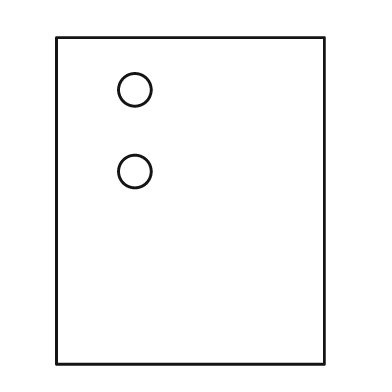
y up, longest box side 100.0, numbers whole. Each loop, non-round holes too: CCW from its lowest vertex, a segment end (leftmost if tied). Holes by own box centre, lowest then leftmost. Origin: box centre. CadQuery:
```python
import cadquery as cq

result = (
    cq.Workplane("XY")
    .moveTo(-41.0, -50.0)
    .lineTo(41.0, -50.0)
    .lineTo(41.0, 50.0)
    .lineTo(-41.0, 50.0)
    .close()
    .moveTo(-17.0, 9.0)
    .circle(5.0)
    .moveTo(-17.0, 34.0)
    .circle(5.0)
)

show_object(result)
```